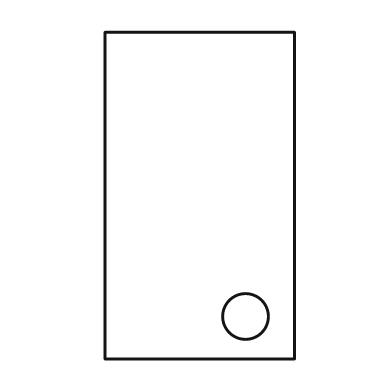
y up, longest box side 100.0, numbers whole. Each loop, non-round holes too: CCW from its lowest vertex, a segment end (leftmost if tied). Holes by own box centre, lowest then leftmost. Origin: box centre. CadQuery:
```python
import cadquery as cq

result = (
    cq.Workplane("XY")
    .moveTo(-29.0, -50.0)
    .lineTo(29.0, -50.0)
    .lineTo(29.0, 50.0)
    .lineTo(-29.0, 50.0)
    .close()
    .moveTo(14.0, -37.0)
    .circle(7.0)
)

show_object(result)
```